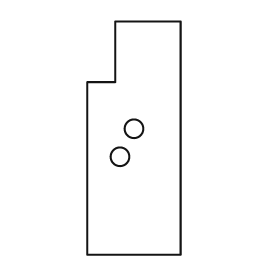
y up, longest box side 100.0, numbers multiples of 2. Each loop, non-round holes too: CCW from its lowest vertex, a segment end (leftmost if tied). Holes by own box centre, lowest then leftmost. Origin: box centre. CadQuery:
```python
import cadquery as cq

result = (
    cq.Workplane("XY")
    .moveTo(-20.0, -50.0)
    .lineTo(20.0, -50.0)
    .lineTo(20.0, 50.0)
    .lineTo(-8.0, 50.0)
    .lineTo(-8.0, 24.0)
    .lineTo(-20.0, 24.0)
    .close()
    .moveTo(-6.0, -8.0)
    .circle(4.0)
    .moveTo(0.0, 4.0)
    .circle(4.0)
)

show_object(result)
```